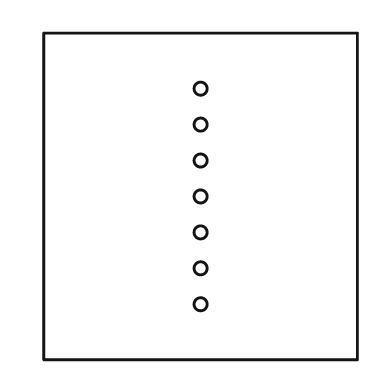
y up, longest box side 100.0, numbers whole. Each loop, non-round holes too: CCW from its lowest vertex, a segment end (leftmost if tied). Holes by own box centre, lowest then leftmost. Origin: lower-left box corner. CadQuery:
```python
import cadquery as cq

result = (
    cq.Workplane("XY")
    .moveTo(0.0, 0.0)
    .lineTo(96.0, 0.0)
    .lineTo(96.0, 100.0)
    .lineTo(0.0, 100.0)
    .close()
    .moveTo(48.0, 17.0)
    .circle(2.0)
    .moveTo(48.0, 28.0)
    .circle(2.0)
    .moveTo(48.0, 39.0)
    .circle(2.0)
    .moveTo(48.0, 50.0)
    .circle(2.0)
    .moveTo(48.0, 61.0)
    .circle(2.0)
    .moveTo(48.0, 72.0)
    .circle(2.0)
    .moveTo(48.0, 83.0)
    .circle(2.0)
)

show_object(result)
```